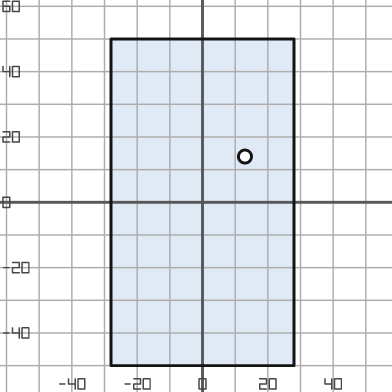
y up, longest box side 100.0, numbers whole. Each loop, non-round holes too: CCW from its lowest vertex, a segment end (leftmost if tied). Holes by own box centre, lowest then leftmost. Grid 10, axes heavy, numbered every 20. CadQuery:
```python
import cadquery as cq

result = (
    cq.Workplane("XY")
    .moveTo(-28.0, -50.0)
    .lineTo(28.0, -50.0)
    .lineTo(28.0, 50.0)
    .lineTo(-28.0, 50.0)
    .close()
    .moveTo(13.0, 14.0)
    .circle(2.0)
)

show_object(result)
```